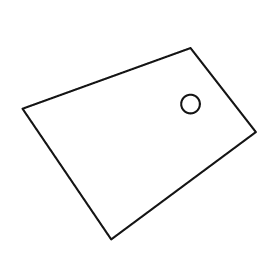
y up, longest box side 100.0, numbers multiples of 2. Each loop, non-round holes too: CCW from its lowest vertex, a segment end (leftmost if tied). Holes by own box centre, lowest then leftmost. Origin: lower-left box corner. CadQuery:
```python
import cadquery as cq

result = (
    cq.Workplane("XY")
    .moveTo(38.0, 0.0)
    .lineTo(100.0, 46.0)
    .lineTo(72.0, 82.0)
    .lineTo(0.0, 56.0)
    .close()
    .moveTo(72.0, 58.0)
    .circle(4.0)
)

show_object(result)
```